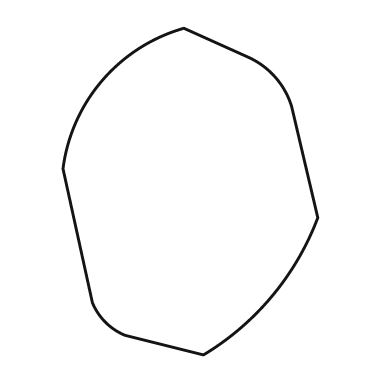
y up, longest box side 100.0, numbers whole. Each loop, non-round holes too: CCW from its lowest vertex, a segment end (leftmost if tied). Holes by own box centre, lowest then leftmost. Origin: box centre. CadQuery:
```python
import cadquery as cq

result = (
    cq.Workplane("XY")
    .moveTo(4.0, -50.0)
    .threePointArc((25.0, -32.0), (39.0, -8.0))
    .lineTo(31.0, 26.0)
    .threePointArc((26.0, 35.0), (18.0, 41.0))
    .lineTo(-2.0, 50.0)
    .threePointArc((-27.0, 34.0), (-39.0, 7.0))
    .lineTo(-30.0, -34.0)
    .threePointArc((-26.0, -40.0), (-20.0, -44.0))
    .close()
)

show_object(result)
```